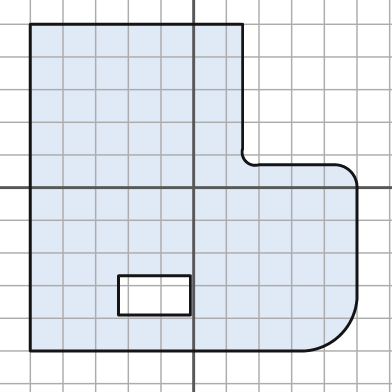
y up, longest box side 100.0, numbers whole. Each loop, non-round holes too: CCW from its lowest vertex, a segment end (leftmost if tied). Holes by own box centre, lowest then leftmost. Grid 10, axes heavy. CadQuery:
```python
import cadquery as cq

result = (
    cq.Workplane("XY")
    .moveTo(-50.0, -50.0)
    .lineTo(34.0, -50.0)
    .threePointArc((45.0, -45.0), (50.0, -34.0))
    .lineTo(50.0, 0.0)
    .threePointArc((48.0, 5.0), (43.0, 7.0))
    .lineTo(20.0, 7.0)
    .threePointArc((16.0, 8.0), (15.0, 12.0))
    .lineTo(15.0, 50.0)
    .lineTo(-50.0, 50.0)
    .close()
    .moveTo(-23.0, -39.0)
    .lineTo(-1.0, -39.0)
    .lineTo(-1.0, -27.0)
    .lineTo(-23.0, -27.0)
    .close()
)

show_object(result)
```